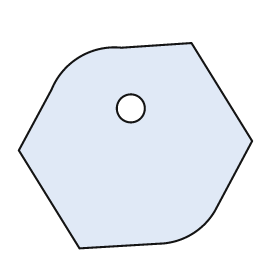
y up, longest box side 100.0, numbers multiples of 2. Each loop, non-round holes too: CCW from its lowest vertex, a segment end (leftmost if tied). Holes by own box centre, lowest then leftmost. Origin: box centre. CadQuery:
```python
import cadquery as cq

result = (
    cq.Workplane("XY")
    .moveTo(-24.0, -44.0)
    .lineTo(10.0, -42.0)
    .threePointArc((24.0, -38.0), (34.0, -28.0))
    .lineTo(50.0, 2.0)
    .lineTo(24.0, 44.0)
    .lineTo(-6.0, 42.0)
    .threePointArc((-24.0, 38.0), (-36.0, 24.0))
    .lineTo(-50.0, -2.0)
    .close()
    .moveTo(-2.0, 16.0)
    .circle(6.0)
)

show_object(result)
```